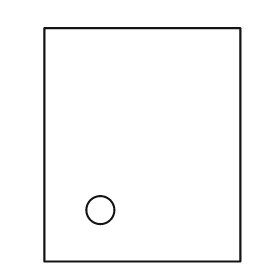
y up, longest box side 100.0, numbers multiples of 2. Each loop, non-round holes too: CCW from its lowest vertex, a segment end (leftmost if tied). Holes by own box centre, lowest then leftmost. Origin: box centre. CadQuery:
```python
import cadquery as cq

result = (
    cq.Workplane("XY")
    .moveTo(-42.0, -50.0)
    .lineTo(42.0, -50.0)
    .lineTo(42.0, 50.0)
    .lineTo(-42.0, 50.0)
    .close()
    .moveTo(-18.0, -28.0)
    .circle(6.0)
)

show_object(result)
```